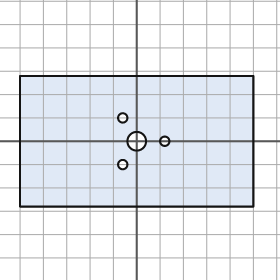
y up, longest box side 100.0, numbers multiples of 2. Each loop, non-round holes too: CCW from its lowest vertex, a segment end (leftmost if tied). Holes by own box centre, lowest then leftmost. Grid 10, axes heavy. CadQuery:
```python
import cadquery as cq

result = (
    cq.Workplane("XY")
    .moveTo(-50.0, -28.0)
    .lineTo(50.0, -28.0)
    .lineTo(50.0, 28.0)
    .lineTo(-50.0, 28.0)
    .close()
    .moveTo(-6.0, -10.0)
    .circle(2.0)
    .moveTo(0.0, 0.0)
    .circle(4.0)
    .moveTo(12.0, 0.0)
    .circle(2.0)
    .moveTo(-6.0, 10.0)
    .circle(2.0)
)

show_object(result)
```